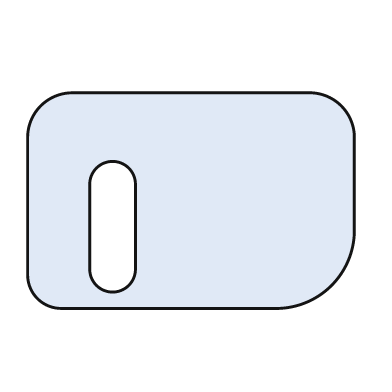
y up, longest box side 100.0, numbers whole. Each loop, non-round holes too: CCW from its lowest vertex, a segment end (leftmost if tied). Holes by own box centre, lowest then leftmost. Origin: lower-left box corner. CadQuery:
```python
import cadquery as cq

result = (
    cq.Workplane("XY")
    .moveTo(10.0, 0.0)
    .lineTo(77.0, 0.0)
    .threePointArc((93.0, 7.0), (100.0, 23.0))
    .lineTo(100.0, 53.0)
    .threePointArc((96.0, 62.0), (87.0, 66.0))
    .lineTo(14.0, 66.0)
    .threePointArc((4.0, 62.0), (0.0, 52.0))
    .lineTo(0.0, 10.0)
    .threePointArc((3.0, 3.0), (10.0, 0.0))
    .close()
    .moveTo(19.0, 12.0)
    .threePointArc((26.0, 5.0), (33.0, 12.0))
    .lineTo(33.0, 38.0)
    .threePointArc((26.0, 45.0), (19.0, 38.0))
    .close()
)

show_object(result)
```